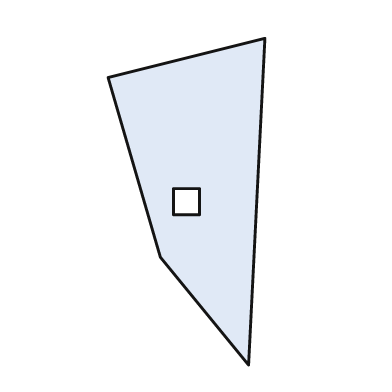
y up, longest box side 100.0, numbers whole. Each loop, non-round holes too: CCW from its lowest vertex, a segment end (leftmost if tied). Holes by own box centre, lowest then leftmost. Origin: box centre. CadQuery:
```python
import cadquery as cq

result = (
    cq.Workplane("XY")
    .moveTo(19.0, -50.0)
    .lineTo(24.0, 50.0)
    .lineTo(-24.0, 38.0)
    .lineTo(-8.0, -17.0)
    .close()
    .moveTo(-4.0, -4.0)
    .lineTo(4.0, -4.0)
    .lineTo(4.0, 4.0)
    .lineTo(-4.0, 4.0)
    .close()
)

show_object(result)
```